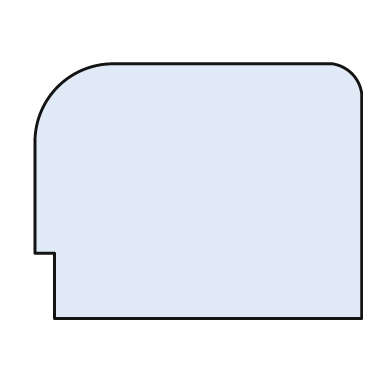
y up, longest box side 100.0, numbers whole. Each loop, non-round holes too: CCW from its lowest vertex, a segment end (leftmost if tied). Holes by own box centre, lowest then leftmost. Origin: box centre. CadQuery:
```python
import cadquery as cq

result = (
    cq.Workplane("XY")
    .moveTo(-44.0, -39.0)
    .lineTo(50.0, -39.0)
    .lineTo(50.0, 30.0)
    .threePointArc((47.0, 36.0), (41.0, 39.0))
    .lineTo(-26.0, 39.0)
    .threePointArc((-43.0, 32.0), (-50.0, 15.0))
    .lineTo(-50.0, -19.0)
    .lineTo(-44.0, -19.0)
    .close()
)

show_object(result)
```